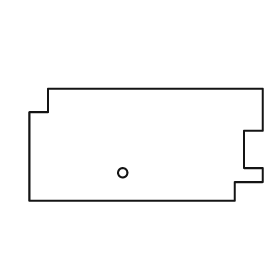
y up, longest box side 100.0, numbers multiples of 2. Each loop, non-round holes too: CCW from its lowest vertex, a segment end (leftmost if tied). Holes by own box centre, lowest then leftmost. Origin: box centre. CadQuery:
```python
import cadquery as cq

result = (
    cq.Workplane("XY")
    .moveTo(-50.0, -24.0)
    .lineTo(38.0, -24.0)
    .lineTo(38.0, -16.0)
    .lineTo(50.0, -16.0)
    .lineTo(50.0, -10.0)
    .lineTo(42.0, -10.0)
    .lineTo(42.0, 6.0)
    .lineTo(50.0, 6.0)
    .lineTo(50.0, 24.0)
    .lineTo(-42.0, 24.0)
    .lineTo(-42.0, 14.0)
    .lineTo(-50.0, 14.0)
    .close()
    .moveTo(-10.0, -12.0)
    .circle(2.0)
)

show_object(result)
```